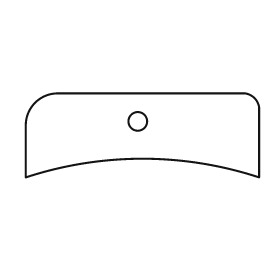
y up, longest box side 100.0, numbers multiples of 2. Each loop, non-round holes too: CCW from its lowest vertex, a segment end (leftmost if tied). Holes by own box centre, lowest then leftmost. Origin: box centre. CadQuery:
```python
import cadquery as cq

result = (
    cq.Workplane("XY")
    .moveTo(-50.0, -18.0)
    .threePointArc((0.0, -10.0), (50.0, -18.0))
    .lineTo(50.0, 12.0)
    .threePointArc((48.0, 16.0), (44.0, 18.0))
    .lineTo(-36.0, 18.0)
    .threePointArc((-46.0, 14.0), (-50.0, 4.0))
    .close()
    .moveTo(-2.0, 6.0)
    .circle(4.0)
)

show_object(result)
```